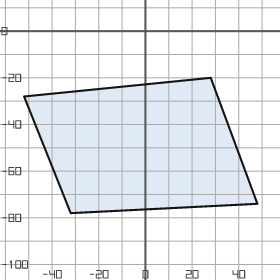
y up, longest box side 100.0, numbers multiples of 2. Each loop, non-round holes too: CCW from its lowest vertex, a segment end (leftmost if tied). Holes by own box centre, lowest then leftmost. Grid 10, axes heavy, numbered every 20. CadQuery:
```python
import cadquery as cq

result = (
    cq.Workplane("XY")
    .moveTo(-32.0, -78.0)
    .lineTo(48.0, -74.0)
    .lineTo(28.0, -20.0)
    .lineTo(-52.0, -28.0)
    .close()
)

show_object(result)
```